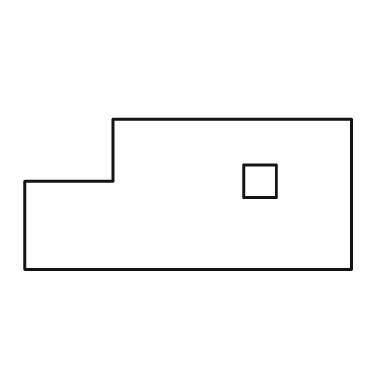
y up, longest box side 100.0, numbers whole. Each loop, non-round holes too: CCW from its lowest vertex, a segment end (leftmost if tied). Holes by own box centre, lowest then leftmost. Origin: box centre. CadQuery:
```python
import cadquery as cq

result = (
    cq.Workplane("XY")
    .moveTo(-50.0, -23.0)
    .lineTo(50.0, -23.0)
    .lineTo(50.0, 23.0)
    .lineTo(-23.0, 23.0)
    .lineTo(-23.0, 4.0)
    .lineTo(-50.0, 4.0)
    .close()
    .moveTo(17.0, -1.0)
    .lineTo(27.0, -1.0)
    .lineTo(27.0, 9.0)
    .lineTo(17.0, 9.0)
    .close()
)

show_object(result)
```